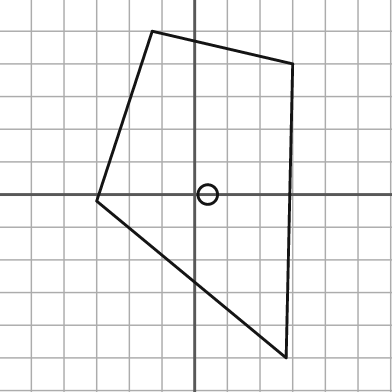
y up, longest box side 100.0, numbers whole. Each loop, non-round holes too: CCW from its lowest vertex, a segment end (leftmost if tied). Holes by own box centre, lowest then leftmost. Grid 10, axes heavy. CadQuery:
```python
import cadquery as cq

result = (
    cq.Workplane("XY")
    .moveTo(28.0, -50.0)
    .lineTo(30.0, 40.0)
    .lineTo(-13.0, 50.0)
    .lineTo(-30.0, -2.0)
    .close()
    .moveTo(4.0, 0.0)
    .circle(3.0)
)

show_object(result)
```